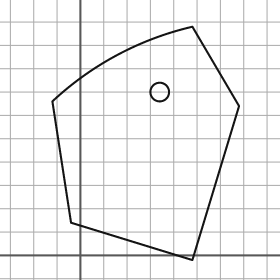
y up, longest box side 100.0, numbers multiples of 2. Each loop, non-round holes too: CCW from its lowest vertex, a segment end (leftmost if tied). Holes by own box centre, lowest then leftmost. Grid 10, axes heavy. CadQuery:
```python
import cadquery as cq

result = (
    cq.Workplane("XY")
    .moveTo(48.0, -2.0)
    .lineTo(68.0, 64.0)
    .lineTo(48.0, 98.0)
    .threePointArc((16.0, 86.0), (-12.0, 66.0))
    .lineTo(-4.0, 14.0)
    .close()
    .moveTo(34.0, 70.0)
    .circle(4.0)
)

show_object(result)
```